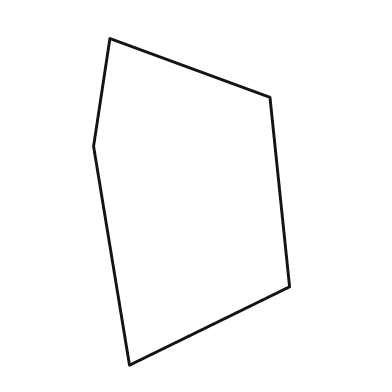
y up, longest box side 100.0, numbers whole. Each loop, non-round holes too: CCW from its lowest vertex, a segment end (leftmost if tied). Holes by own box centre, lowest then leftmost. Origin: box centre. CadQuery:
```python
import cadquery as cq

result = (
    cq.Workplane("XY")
    .moveTo(-19.0, -50.0)
    .lineTo(30.0, -26.0)
    .lineTo(24.0, 32.0)
    .lineTo(-25.0, 50.0)
    .lineTo(-30.0, 17.0)
    .close()
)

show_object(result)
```